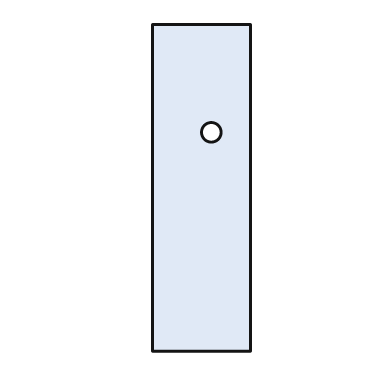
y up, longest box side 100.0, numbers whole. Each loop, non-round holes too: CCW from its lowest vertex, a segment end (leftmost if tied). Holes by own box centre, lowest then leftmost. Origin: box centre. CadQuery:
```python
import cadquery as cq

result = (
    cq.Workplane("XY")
    .moveTo(-15.0, -50.0)
    .lineTo(15.0, -50.0)
    .lineTo(15.0, 50.0)
    .lineTo(-15.0, 50.0)
    .close()
    .moveTo(3.0, 17.0)
    .circle(3.0)
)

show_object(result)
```